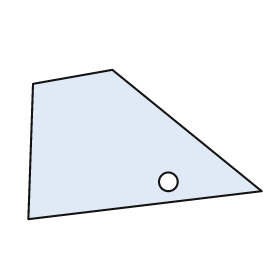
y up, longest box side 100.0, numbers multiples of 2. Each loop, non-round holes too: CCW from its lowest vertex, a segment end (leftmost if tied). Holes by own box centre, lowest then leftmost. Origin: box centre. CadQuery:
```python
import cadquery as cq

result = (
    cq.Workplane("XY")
    .moveTo(-50.0, -32.0)
    .lineTo(50.0, -20.0)
    .lineTo(-14.0, 32.0)
    .lineTo(-48.0, 26.0)
    .close()
    .moveTo(10.0, -16.0)
    .circle(4.0)
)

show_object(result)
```